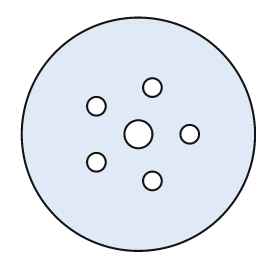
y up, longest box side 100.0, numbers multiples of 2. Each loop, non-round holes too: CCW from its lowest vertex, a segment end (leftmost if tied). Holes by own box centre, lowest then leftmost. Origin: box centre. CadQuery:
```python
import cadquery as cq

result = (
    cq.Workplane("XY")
    .moveTo(0.0, 0.0)
    .circle(50.0)
    .moveTo(6.0, -20.0)
    .circle(4.0)
    .moveTo(-18.0, -12.0)
    .circle(4.0)
    .moveTo(0.0, 0.0)
    .circle(6.0)
    .moveTo(22.0, 0.0)
    .circle(4.0)
    .moveTo(-18.0, 12.0)
    .circle(4.0)
    .moveTo(6.0, 20.0)
    .circle(4.0)
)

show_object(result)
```